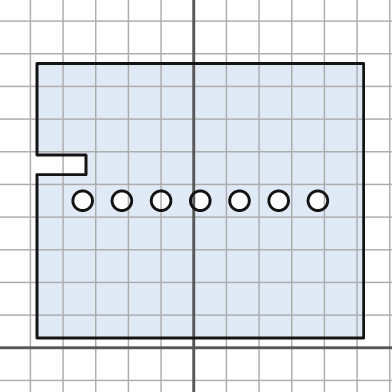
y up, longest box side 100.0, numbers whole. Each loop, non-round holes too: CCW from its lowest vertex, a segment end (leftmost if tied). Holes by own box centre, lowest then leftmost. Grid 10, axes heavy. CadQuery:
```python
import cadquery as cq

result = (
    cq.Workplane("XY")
    .moveTo(-48.0, 3.0)
    .lineTo(52.0, 3.0)
    .lineTo(52.0, 87.0)
    .lineTo(-48.0, 87.0)
    .lineTo(-48.0, 59.0)
    .lineTo(-33.0, 59.0)
    .lineTo(-33.0, 53.0)
    .lineTo(-48.0, 53.0)
    .close()
    .moveTo(-34.0, 45.0)
    .circle(3.0)
    .moveTo(-22.0, 45.0)
    .circle(3.0)
    .moveTo(-10.0, 45.0)
    .circle(3.0)
    .moveTo(2.0, 45.0)
    .circle(3.0)
    .moveTo(14.0, 45.0)
    .circle(3.0)
    .moveTo(26.0, 45.0)
    .circle(3.0)
    .moveTo(38.0, 45.0)
    .circle(3.0)
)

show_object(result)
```